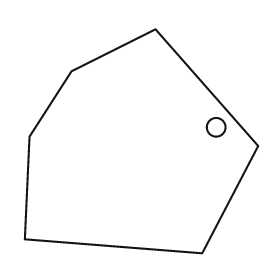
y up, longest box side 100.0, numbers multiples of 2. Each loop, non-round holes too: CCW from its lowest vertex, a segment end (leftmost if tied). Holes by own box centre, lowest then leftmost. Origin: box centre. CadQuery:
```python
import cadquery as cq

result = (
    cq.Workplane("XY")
    .moveTo(26.0, -48.0)
    .lineTo(50.0, -2.0)
    .lineTo(6.0, 48.0)
    .lineTo(-30.0, 30.0)
    .lineTo(-48.0, 2.0)
    .lineTo(-50.0, -42.0)
    .close()
    .moveTo(32.0, 6.0)
    .circle(4.0)
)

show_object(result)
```